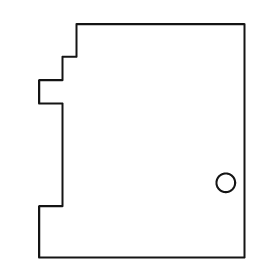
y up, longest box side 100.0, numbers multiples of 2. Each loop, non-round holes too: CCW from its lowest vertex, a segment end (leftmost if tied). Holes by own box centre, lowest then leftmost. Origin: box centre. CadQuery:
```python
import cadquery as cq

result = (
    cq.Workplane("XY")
    .moveTo(-44.0, -50.0)
    .lineTo(44.0, -50.0)
    .lineTo(44.0, 50.0)
    .lineTo(-28.0, 50.0)
    .lineTo(-28.0, 36.0)
    .lineTo(-34.0, 36.0)
    .lineTo(-34.0, 26.0)
    .lineTo(-44.0, 26.0)
    .lineTo(-44.0, 16.0)
    .lineTo(-34.0, 16.0)
    .lineTo(-34.0, -28.0)
    .lineTo(-44.0, -28.0)
    .close()
    .moveTo(36.0, -18.0)
    .circle(4.0)
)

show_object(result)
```